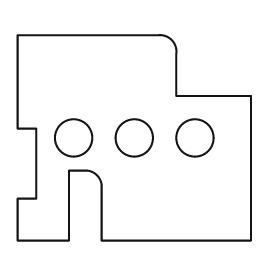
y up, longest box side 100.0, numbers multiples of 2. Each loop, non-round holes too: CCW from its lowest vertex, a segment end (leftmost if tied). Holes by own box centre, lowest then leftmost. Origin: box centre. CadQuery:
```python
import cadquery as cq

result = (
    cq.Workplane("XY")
    .moveTo(-50.0, -44.0)
    .lineTo(-28.0, -44.0)
    .lineTo(-28.0, -14.0)
    .lineTo(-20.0, -14.0)
    .threePointArc((-16.0, -16.0), (-14.0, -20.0))
    .lineTo(-14.0, -44.0)
    .lineTo(50.0, -44.0)
    .lineTo(50.0, 18.0)
    .lineTo(18.0, 18.0)
    .lineTo(18.0, 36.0)
    .threePointArc((16.0, 42.0), (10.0, 44.0))
    .lineTo(-50.0, 44.0)
    .lineTo(-50.0, 4.0)
    .lineTo(-42.0, 4.0)
    .lineTo(-42.0, -26.0)
    .lineTo(-50.0, -26.0)
    .close()
    .moveTo(-26.0, 0.0)
    .circle(8.0)
    .moveTo(0.0, 0.0)
    .circle(8.0)
    .moveTo(26.0, 0.0)
    .circle(8.0)
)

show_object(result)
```